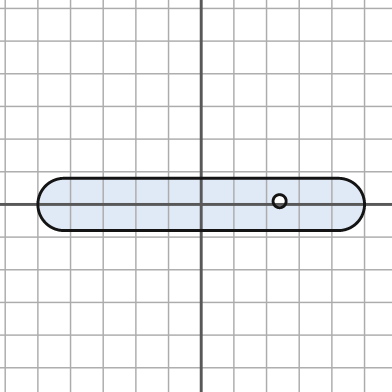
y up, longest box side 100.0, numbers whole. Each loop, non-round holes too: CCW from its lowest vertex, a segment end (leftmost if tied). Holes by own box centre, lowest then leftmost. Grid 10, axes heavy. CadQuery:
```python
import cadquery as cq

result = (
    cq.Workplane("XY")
    .moveTo(-42.0, -8.0)
    .lineTo(42.0, -8.0)
    .threePointArc((50.0, 0.0), (42.0, 8.0))
    .lineTo(-42.0, 8.0)
    .threePointArc((-50.0, 0.0), (-42.0, -8.0))
    .close()
    .moveTo(24.0, 1.0)
    .circle(2.0)
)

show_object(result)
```